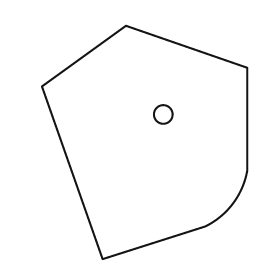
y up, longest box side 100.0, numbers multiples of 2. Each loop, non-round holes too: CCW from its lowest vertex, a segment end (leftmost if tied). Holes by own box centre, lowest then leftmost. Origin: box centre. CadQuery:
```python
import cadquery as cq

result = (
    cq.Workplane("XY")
    .moveTo(-18.0, -50.0)
    .lineTo(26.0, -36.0)
    .threePointArc((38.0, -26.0), (44.0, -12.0))
    .lineTo(44.0, 32.0)
    .lineTo(-8.0, 50.0)
    .lineTo(-44.0, 24.0)
    .close()
    .moveTo(8.0, 12.0)
    .circle(4.0)
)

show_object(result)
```